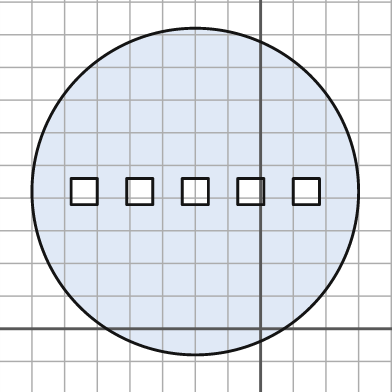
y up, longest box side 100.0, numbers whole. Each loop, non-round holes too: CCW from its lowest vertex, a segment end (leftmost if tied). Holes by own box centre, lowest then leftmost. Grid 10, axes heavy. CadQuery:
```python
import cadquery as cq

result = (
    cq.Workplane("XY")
    .moveTo(-20.0, 42.0)
    .circle(50.0)
    .moveTo(-58.0, 38.0)
    .lineTo(-50.0, 38.0)
    .lineTo(-50.0, 46.0)
    .lineTo(-58.0, 46.0)
    .close()
    .moveTo(-41.0, 38.0)
    .lineTo(-33.0, 38.0)
    .lineTo(-33.0, 46.0)
    .lineTo(-41.0, 46.0)
    .close()
    .moveTo(-24.0, 38.0)
    .lineTo(-16.0, 38.0)
    .lineTo(-16.0, 46.0)
    .lineTo(-24.0, 46.0)
    .close()
    .moveTo(-7.0, 38.0)
    .lineTo(1.0, 38.0)
    .lineTo(1.0, 46.0)
    .lineTo(-7.0, 46.0)
    .close()
    .moveTo(10.0, 38.0)
    .lineTo(18.0, 38.0)
    .lineTo(18.0, 46.0)
    .lineTo(10.0, 46.0)
    .close()
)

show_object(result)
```